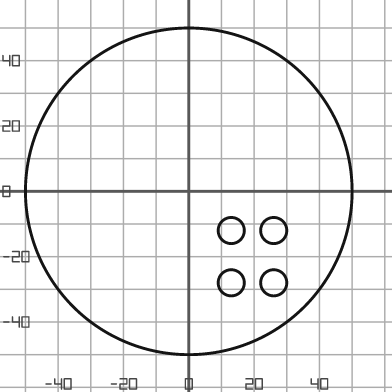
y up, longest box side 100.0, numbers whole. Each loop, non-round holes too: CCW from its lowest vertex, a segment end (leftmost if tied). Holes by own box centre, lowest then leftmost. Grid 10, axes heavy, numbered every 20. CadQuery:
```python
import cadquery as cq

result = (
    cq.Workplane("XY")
    .moveTo(0.0, 0.0)
    .circle(50.0)
    .moveTo(13.0, -28.0)
    .circle(4.0)
    .moveTo(26.0, -28.0)
    .circle(4.0)
    .moveTo(13.0, -12.0)
    .circle(4.0)
    .moveTo(26.0, -12.0)
    .circle(4.0)
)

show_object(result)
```